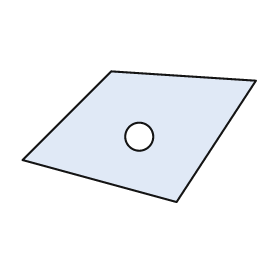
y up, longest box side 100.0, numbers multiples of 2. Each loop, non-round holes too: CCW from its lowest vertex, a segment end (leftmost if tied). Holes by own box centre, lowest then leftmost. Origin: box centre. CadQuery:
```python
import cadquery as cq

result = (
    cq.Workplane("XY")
    .moveTo(16.0, -28.0)
    .lineTo(50.0, 24.0)
    .lineTo(-12.0, 28.0)
    .lineTo(-50.0, -10.0)
    .close()
    .moveTo(0.0, 0.0)
    .circle(6.0)
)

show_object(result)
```